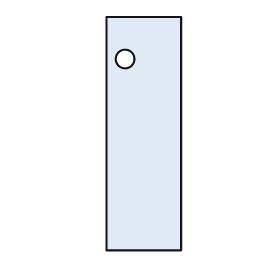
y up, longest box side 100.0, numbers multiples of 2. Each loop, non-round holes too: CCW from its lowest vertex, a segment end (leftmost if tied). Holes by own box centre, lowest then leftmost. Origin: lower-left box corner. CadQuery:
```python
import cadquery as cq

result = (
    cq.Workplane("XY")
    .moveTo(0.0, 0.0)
    .lineTo(32.0, 0.0)
    .lineTo(32.0, 100.0)
    .lineTo(0.0, 100.0)
    .close()
    .moveTo(8.0, 82.0)
    .circle(4.0)
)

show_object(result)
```